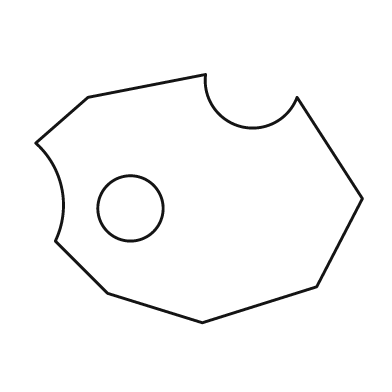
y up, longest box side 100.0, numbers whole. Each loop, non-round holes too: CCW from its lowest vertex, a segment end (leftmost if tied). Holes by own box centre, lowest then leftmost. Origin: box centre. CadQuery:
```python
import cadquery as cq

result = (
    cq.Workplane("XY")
    .moveTo(1.0, -38.0)
    .lineTo(36.0, -27.0)
    .lineTo(50.0, 0.0)
    .lineTo(30.0, 31.0)
    .threePointArc((13.0, 22.0), (2.0, 38.0))
    .lineTo(-34.0, 31.0)
    .lineTo(-50.0, 17.0)
    .threePointArc((-42.0, 3.0), (-44.0, -13.0))
    .lineTo(-28.0, -29.0)
    .close()
    .moveTo(-21.0, -3.0)
    .circle(10.0)
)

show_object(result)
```